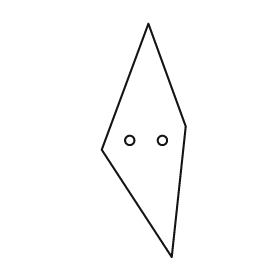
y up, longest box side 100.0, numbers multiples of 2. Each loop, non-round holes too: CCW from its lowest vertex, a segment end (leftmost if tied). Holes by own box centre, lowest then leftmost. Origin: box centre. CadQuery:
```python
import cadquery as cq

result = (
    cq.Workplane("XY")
    .moveTo(12.0, -50.0)
    .lineTo(18.0, 6.0)
    .lineTo(2.0, 50.0)
    .lineTo(-18.0, -4.0)
    .close()
    .moveTo(-6.0, 0.0)
    .circle(2.0)
    .moveTo(8.0, 0.0)
    .circle(2.0)
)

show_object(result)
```